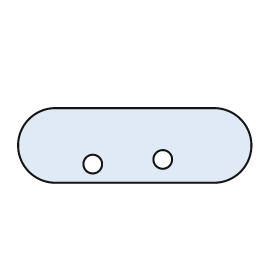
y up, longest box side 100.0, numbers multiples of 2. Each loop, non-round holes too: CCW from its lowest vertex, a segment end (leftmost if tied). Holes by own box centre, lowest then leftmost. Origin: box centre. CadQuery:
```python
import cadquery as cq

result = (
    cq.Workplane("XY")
    .moveTo(-34.0, -16.0)
    .lineTo(34.0, -16.0)
    .threePointArc((50.0, 0.0), (34.0, 16.0))
    .lineTo(-34.0, 16.0)
    .threePointArc((-50.0, 0.0), (-34.0, -16.0))
    .close()
    .moveTo(-18.0, -8.0)
    .circle(4.0)
    .moveTo(12.0, -6.0)
    .circle(4.0)
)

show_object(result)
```